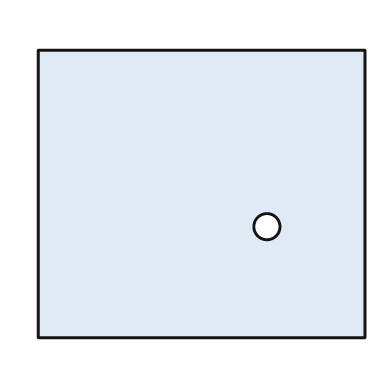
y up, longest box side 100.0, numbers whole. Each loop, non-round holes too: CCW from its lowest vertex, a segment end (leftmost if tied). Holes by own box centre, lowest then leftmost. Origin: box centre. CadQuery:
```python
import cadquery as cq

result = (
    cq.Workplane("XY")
    .moveTo(-50.0, -44.0)
    .lineTo(50.0, -44.0)
    .lineTo(50.0, 44.0)
    .lineTo(-50.0, 44.0)
    .close()
    .moveTo(20.0, -10.0)
    .circle(4.0)
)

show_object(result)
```